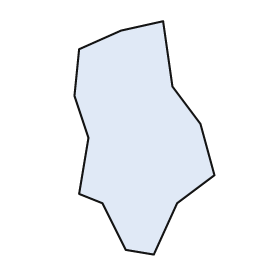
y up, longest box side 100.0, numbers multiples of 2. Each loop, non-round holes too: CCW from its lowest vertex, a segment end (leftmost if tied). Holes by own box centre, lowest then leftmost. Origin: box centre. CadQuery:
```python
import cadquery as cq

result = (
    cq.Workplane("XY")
    .moveTo(4.0, -50.0)
    .lineTo(14.0, -28.0)
    .lineTo(30.0, -16.0)
    .lineTo(24.0, 6.0)
    .lineTo(12.0, 22.0)
    .lineTo(8.0, 50.0)
    .lineTo(-10.0, 46.0)
    .lineTo(-28.0, 38.0)
    .lineTo(-30.0, 18.0)
    .lineTo(-24.0, 0.0)
    .lineTo(-28.0, -24.0)
    .lineTo(-18.0, -28.0)
    .lineTo(-8.0, -48.0)
    .close()
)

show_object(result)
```